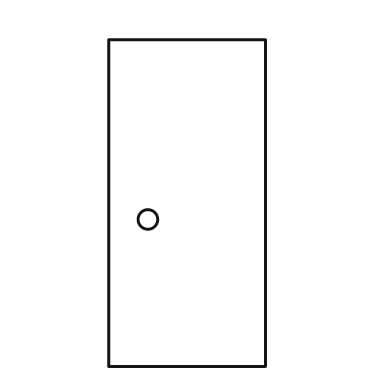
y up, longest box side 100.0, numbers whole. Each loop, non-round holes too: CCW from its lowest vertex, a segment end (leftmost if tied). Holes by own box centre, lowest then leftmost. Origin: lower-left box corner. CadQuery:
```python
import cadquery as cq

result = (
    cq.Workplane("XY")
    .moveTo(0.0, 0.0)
    .lineTo(48.0, 0.0)
    .lineTo(48.0, 100.0)
    .lineTo(0.0, 100.0)
    .close()
    .moveTo(12.0, 45.0)
    .circle(3.0)
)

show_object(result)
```